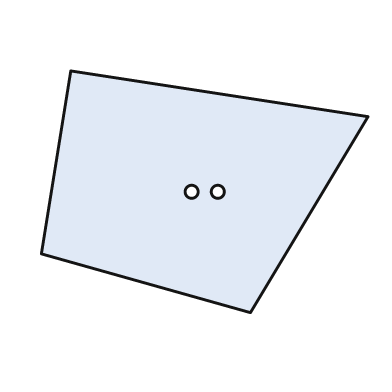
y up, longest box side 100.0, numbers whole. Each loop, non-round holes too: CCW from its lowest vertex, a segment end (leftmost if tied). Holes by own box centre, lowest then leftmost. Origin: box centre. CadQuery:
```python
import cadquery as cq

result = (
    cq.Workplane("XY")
    .moveTo(14.0, -37.0)
    .lineTo(50.0, 23.0)
    .lineTo(-41.0, 37.0)
    .lineTo(-50.0, -19.0)
    .close()
    .moveTo(-4.0, 0.0)
    .circle(2.0)
    .moveTo(4.0, 0.0)
    .circle(2.0)
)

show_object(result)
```